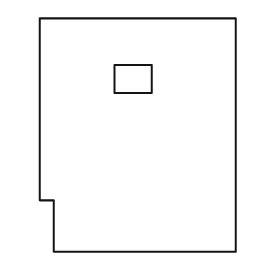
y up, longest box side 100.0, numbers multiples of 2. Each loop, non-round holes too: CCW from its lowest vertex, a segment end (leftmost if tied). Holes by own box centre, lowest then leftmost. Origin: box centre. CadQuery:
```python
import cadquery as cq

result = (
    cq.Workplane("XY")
    .moveTo(-36.0, -50.0)
    .lineTo(42.0, -50.0)
    .lineTo(42.0, 50.0)
    .lineTo(-42.0, 50.0)
    .lineTo(-42.0, -28.0)
    .lineTo(-36.0, -28.0)
    .close()
    .moveTo(-10.0, 18.0)
    .lineTo(6.0, 18.0)
    .lineTo(6.0, 30.0)
    .lineTo(-10.0, 30.0)
    .close()
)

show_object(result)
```